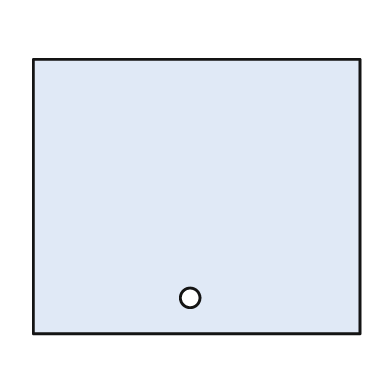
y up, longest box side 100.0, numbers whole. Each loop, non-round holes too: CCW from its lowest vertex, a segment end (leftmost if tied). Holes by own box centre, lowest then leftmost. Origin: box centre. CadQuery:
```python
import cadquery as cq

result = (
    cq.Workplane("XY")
    .moveTo(-50.0, -42.0)
    .lineTo(50.0, -42.0)
    .lineTo(50.0, 42.0)
    .lineTo(-50.0, 42.0)
    .close()
    .moveTo(-2.0, -31.0)
    .circle(3.0)
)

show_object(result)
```